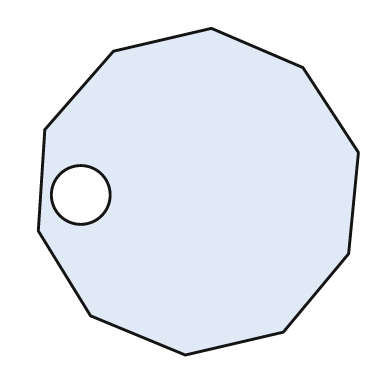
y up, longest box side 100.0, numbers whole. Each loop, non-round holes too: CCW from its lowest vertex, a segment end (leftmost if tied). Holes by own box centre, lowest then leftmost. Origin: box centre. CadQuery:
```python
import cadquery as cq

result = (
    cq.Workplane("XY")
    .moveTo(-4.0, -50.0)
    .lineTo(26.0, -43.0)
    .lineTo(46.0, -19.0)
    .lineTo(49.0, 12.0)
    .lineTo(32.0, 38.0)
    .lineTo(4.0, 50.0)
    .lineTo(-26.0, 43.0)
    .lineTo(-47.0, 19.0)
    .lineTo(-49.0, -12.0)
    .lineTo(-33.0, -38.0)
    .close()
    .moveTo(-36.0, -1.0)
    .circle(9.0)
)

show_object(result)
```